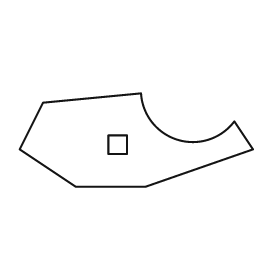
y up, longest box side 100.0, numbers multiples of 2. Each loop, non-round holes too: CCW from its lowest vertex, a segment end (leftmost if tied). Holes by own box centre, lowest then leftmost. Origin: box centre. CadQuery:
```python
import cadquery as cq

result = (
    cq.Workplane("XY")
    .moveTo(-26.0, -20.0)
    .lineTo(4.0, -20.0)
    .lineTo(50.0, -4.0)
    .lineTo(42.0, 8.0)
    .threePointArc((18.0, 0.0), (2.0, 20.0))
    .lineTo(-40.0, 16.0)
    .lineTo(-50.0, -4.0)
    .close()
    .moveTo(-12.0, -6.0)
    .lineTo(-4.0, -6.0)
    .lineTo(-4.0, 2.0)
    .lineTo(-12.0, 2.0)
    .close()
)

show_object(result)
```